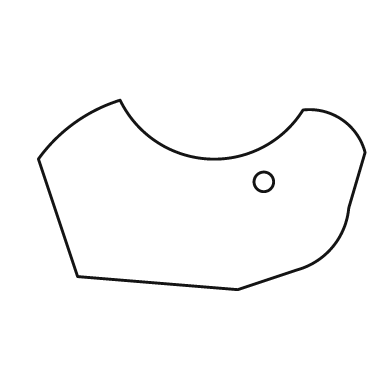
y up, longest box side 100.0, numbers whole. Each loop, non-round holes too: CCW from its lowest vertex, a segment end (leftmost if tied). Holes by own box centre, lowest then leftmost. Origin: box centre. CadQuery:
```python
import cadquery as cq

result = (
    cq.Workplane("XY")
    .moveTo(11.0, -29.0)
    .lineTo(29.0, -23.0)
    .threePointArc((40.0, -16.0), (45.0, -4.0))
    .lineTo(50.0, 13.0)
    .threePointArc((43.0, 23.0), (31.0, 26.0))
    .threePointArc((2.0, 11.0), (-25.0, 29.0))
    .threePointArc((-39.0, 22.0), (-50.0, 11.0))
    .lineTo(-38.0, -25.0)
    .close()
    .moveTo(19.0, 4.0)
    .circle(3.0)
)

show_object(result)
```